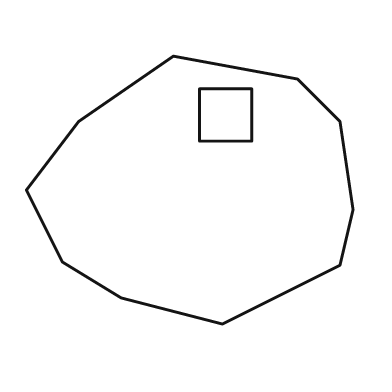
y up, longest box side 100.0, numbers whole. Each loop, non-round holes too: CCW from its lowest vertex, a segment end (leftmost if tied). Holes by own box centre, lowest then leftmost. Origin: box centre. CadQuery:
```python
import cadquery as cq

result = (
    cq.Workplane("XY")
    .moveTo(10.0, -41.0)
    .lineTo(46.0, -23.0)
    .lineTo(50.0, -6.0)
    .lineTo(46.0, 21.0)
    .lineTo(33.0, 34.0)
    .lineTo(-5.0, 41.0)
    .lineTo(-34.0, 21.0)
    .lineTo(-50.0, 0.0)
    .lineTo(-39.0, -22.0)
    .lineTo(-21.0, -33.0)
    .close()
    .moveTo(3.0, 15.0)
    .lineTo(19.0, 15.0)
    .lineTo(19.0, 31.0)
    .lineTo(3.0, 31.0)
    .close()
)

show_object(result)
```